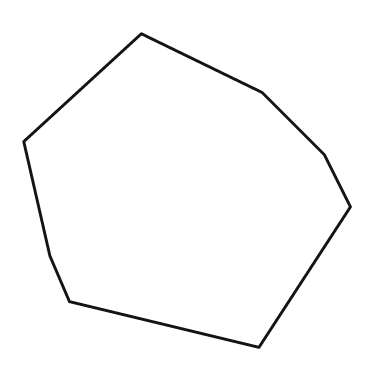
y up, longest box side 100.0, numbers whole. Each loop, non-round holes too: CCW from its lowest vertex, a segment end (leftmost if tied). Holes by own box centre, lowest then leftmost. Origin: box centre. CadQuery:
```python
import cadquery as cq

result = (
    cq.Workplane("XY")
    .moveTo(22.0, -48.0)
    .lineTo(50.0, -5.0)
    .lineTo(42.0, 11.0)
    .lineTo(23.0, 30.0)
    .lineTo(-14.0, 48.0)
    .lineTo(-50.0, 15.0)
    .lineTo(-42.0, -20.0)
    .lineTo(-36.0, -34.0)
    .close()
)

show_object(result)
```